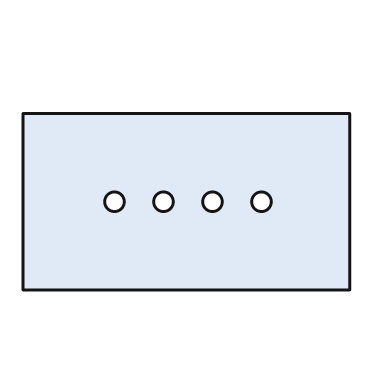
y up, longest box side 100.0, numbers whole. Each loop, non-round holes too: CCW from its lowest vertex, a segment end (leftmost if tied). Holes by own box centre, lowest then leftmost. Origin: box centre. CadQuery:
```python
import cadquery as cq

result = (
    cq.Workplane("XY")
    .moveTo(-50.0, -27.0)
    .lineTo(50.0, -27.0)
    .lineTo(50.0, 27.0)
    .lineTo(-50.0, 27.0)
    .close()
    .moveTo(-22.0, 0.0)
    .circle(3.0)
    .moveTo(-7.0, 0.0)
    .circle(3.0)
    .moveTo(8.0, 0.0)
    .circle(3.0)
    .moveTo(23.0, 0.0)
    .circle(3.0)
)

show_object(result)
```